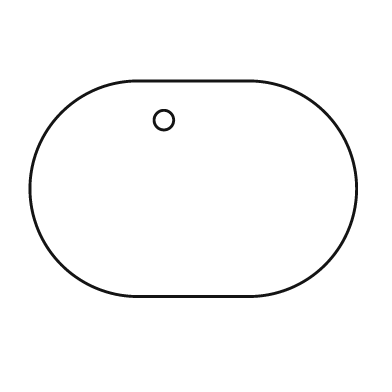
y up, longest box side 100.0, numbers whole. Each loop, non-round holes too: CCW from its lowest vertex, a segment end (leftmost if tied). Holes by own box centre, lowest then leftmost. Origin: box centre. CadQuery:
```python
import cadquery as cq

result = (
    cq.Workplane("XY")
    .moveTo(-17.0, -33.0)
    .lineTo(17.0, -33.0)
    .threePointArc((50.0, 0.0), (17.0, 33.0))
    .lineTo(-17.0, 33.0)
    .threePointArc((-50.0, 0.0), (-17.0, -33.0))
    .close()
    .moveTo(-9.0, 21.0)
    .circle(3.0)
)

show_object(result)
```